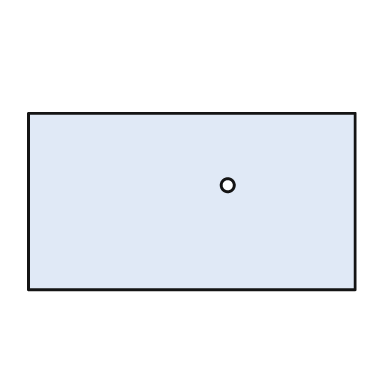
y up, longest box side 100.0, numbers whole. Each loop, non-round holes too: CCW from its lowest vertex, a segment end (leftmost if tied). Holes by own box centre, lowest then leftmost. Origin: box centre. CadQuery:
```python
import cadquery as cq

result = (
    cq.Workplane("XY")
    .moveTo(-50.0, -27.0)
    .lineTo(50.0, -27.0)
    .lineTo(50.0, 27.0)
    .lineTo(-50.0, 27.0)
    .close()
    .moveTo(11.0, 5.0)
    .circle(2.0)
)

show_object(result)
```